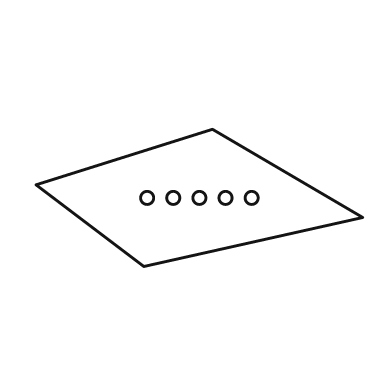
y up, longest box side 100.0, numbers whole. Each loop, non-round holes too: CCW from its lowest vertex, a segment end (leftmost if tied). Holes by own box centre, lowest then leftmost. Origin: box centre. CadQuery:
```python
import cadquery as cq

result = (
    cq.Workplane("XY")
    .moveTo(-17.0, -21.0)
    .lineTo(50.0, -6.0)
    .lineTo(4.0, 21.0)
    .lineTo(-50.0, 4.0)
    .close()
    .moveTo(-16.0, 0.0)
    .circle(2.0)
    .moveTo(-8.0, 0.0)
    .circle(2.0)
    .moveTo(0.0, 0.0)
    .circle(2.0)
    .moveTo(8.0, 0.0)
    .circle(2.0)
    .moveTo(16.0, 0.0)
    .circle(2.0)
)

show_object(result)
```